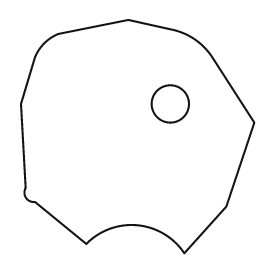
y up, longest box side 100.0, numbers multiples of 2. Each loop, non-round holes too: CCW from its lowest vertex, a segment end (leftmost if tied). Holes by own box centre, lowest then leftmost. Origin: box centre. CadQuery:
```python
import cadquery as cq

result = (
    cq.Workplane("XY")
    .moveTo(20.0, -50.0)
    .lineTo(38.0, -30.0)
    .lineTo(50.0, 6.0)
    .lineTo(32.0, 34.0)
    .threePointArc((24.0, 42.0), (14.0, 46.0))
    .lineTo(-4.0, 50.0)
    .lineTo(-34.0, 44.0)
    .threePointArc((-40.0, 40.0), (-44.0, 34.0))
    .lineTo(-50.0, 14.0)
    .lineTo(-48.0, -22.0)
    .threePointArc((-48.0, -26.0), (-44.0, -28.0))
    .lineTo(-22.0, -46.0)
    .threePointArc((0.0, -38.0), (20.0, -50.0))
    .close()
    .moveTo(14.0, 14.0)
    .circle(8.0)
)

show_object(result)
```